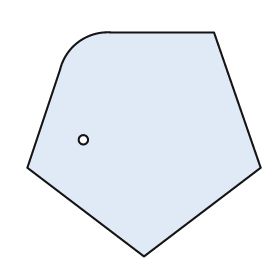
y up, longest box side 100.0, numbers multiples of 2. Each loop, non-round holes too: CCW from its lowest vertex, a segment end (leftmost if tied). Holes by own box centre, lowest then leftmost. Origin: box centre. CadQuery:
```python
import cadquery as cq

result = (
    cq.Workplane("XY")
    .moveTo(0.0, -48.0)
    .lineTo(50.0, -10.0)
    .lineTo(30.0, 48.0)
    .lineTo(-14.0, 48.0)
    .threePointArc((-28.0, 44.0), (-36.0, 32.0))
    .lineTo(-50.0, -10.0)
    .close()
    .moveTo(-26.0, 2.0)
    .circle(2.0)
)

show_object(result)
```